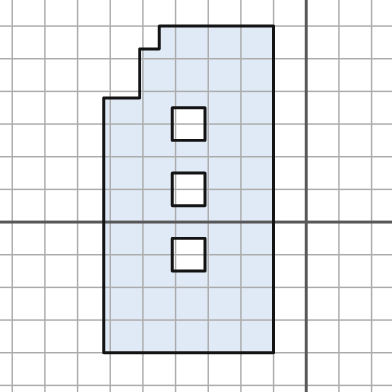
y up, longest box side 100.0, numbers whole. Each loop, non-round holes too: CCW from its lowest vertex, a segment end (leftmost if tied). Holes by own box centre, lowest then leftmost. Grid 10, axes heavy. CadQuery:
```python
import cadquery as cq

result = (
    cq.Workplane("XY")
    .moveTo(-62.0, -40.0)
    .lineTo(-10.0, -40.0)
    .lineTo(-10.0, 60.0)
    .lineTo(-45.0, 60.0)
    .lineTo(-45.0, 53.0)
    .lineTo(-51.0, 53.0)
    .lineTo(-51.0, 38.0)
    .lineTo(-62.0, 38.0)
    .close()
    .moveTo(-41.0, -15.0)
    .lineTo(-31.0, -15.0)
    .lineTo(-31.0, -5.0)
    .lineTo(-41.0, -5.0)
    .close()
    .moveTo(-41.0, 5.0)
    .lineTo(-31.0, 5.0)
    .lineTo(-31.0, 15.0)
    .lineTo(-41.0, 15.0)
    .close()
    .moveTo(-41.0, 25.0)
    .lineTo(-31.0, 25.0)
    .lineTo(-31.0, 35.0)
    .lineTo(-41.0, 35.0)
    .close()
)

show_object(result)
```